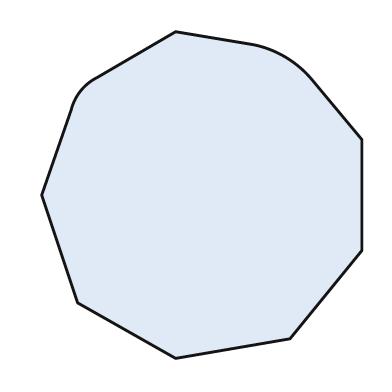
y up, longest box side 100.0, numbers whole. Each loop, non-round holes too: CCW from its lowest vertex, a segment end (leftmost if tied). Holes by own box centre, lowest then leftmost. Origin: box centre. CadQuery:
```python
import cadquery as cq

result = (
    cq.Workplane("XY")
    .moveTo(-8.0, -50.0)
    .lineTo(27.0, -44.0)
    .lineTo(49.0, -17.0)
    .lineTo(49.0, 17.0)
    .lineTo(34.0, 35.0)
    .threePointArc((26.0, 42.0), (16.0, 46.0))
    .lineTo(-8.0, 50.0)
    .lineTo(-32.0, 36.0)
    .threePointArc((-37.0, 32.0), (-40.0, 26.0))
    .lineTo(-49.0, 0.0)
    .lineTo(-38.0, -33.0)
    .close()
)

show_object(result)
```